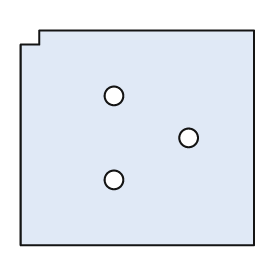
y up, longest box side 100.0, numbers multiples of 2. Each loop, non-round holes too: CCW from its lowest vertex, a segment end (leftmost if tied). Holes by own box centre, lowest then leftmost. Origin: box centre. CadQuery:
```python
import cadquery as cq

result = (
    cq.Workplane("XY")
    .moveTo(-50.0, -46.0)
    .lineTo(50.0, -46.0)
    .lineTo(50.0, 46.0)
    .lineTo(-42.0, 46.0)
    .lineTo(-42.0, 40.0)
    .lineTo(-50.0, 40.0)
    .close()
    .moveTo(-10.0, -18.0)
    .circle(4.0)
    .moveTo(22.0, 0.0)
    .circle(4.0)
    .moveTo(-10.0, 18.0)
    .circle(4.0)
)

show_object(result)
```